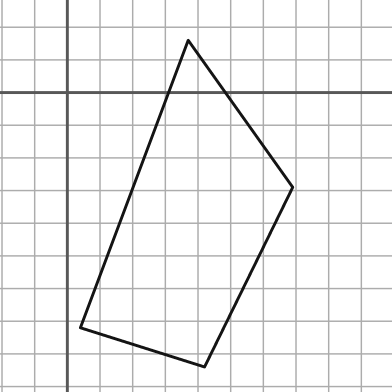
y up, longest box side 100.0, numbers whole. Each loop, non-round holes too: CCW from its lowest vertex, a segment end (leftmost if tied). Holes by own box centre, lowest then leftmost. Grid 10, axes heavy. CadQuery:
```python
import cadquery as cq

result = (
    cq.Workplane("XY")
    .moveTo(42.0, -84.0)
    .lineTo(69.0, -29.0)
    .lineTo(37.0, 16.0)
    .lineTo(4.0, -72.0)
    .close()
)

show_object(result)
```